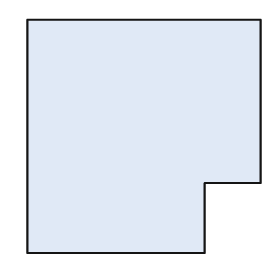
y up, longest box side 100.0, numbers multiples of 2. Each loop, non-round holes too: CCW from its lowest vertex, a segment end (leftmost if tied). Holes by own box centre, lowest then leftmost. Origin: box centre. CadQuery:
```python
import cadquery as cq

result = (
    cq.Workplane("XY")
    .moveTo(-50.0, -50.0)
    .lineTo(26.0, -50.0)
    .lineTo(26.0, -20.0)
    .lineTo(50.0, -20.0)
    .lineTo(50.0, 50.0)
    .lineTo(-50.0, 50.0)
    .close()
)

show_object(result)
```